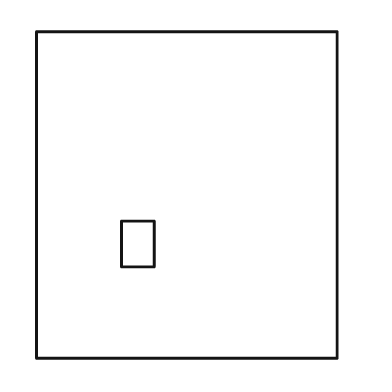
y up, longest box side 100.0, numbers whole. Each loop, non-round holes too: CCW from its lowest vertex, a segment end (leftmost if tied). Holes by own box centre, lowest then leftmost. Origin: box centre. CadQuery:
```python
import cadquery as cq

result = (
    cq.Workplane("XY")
    .moveTo(-46.0, -50.0)
    .lineTo(46.0, -50.0)
    .lineTo(46.0, 50.0)
    .lineTo(-46.0, 50.0)
    .close()
    .moveTo(-20.0, -22.0)
    .lineTo(-10.0, -22.0)
    .lineTo(-10.0, -8.0)
    .lineTo(-20.0, -8.0)
    .close()
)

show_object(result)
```